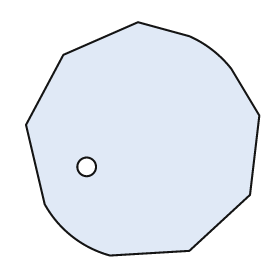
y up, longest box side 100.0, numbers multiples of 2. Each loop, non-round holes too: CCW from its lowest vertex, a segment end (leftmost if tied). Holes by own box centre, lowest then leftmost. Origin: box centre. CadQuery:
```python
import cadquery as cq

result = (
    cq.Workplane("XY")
    .moveTo(-14.0, -50.0)
    .lineTo(20.0, -48.0)
    .lineTo(46.0, -24.0)
    .lineTo(50.0, 10.0)
    .lineTo(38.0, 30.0)
    .threePointArc((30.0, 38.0), (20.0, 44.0))
    .lineTo(-2.0, 50.0)
    .lineTo(-34.0, 36.0)
    .lineTo(-50.0, 6.0)
    .lineTo(-42.0, -28.0)
    .threePointArc((-30.0, -42.0), (-14.0, -50.0))
    .close()
    .moveTo(-24.0, -12.0)
    .circle(4.0)
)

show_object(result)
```